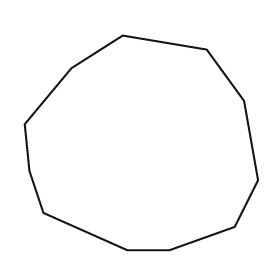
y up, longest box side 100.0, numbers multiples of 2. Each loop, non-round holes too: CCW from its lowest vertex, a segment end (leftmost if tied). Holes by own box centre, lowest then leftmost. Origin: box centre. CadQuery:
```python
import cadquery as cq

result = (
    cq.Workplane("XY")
    .moveTo(-6.0, -46.0)
    .lineTo(12.0, -46.0)
    .lineTo(40.0, -36.0)
    .lineTo(50.0, -16.0)
    .lineTo(44.0, 18.0)
    .lineTo(28.0, 40.0)
    .lineTo(-8.0, 46.0)
    .lineTo(-30.0, 32.0)
    .lineTo(-50.0, 8.0)
    .lineTo(-48.0, -12.0)
    .lineTo(-42.0, -30.0)
    .close()
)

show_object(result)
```